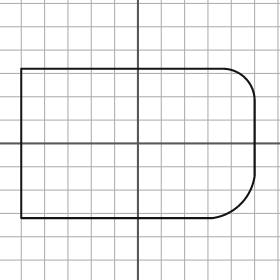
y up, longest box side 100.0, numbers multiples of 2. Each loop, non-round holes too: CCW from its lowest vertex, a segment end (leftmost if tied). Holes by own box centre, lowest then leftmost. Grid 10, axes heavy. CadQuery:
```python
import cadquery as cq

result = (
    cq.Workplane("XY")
    .moveTo(-50.0, -32.0)
    .lineTo(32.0, -32.0)
    .threePointArc((44.0, -26.0), (50.0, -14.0))
    .lineTo(50.0, 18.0)
    .threePointArc((46.0, 28.0), (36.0, 32.0))
    .lineTo(-50.0, 32.0)
    .close()
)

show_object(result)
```